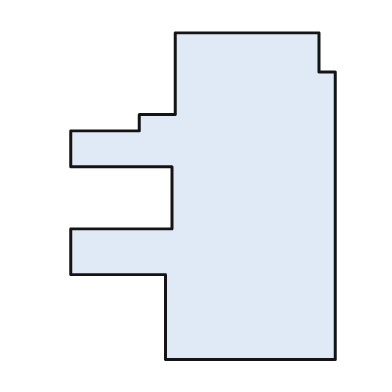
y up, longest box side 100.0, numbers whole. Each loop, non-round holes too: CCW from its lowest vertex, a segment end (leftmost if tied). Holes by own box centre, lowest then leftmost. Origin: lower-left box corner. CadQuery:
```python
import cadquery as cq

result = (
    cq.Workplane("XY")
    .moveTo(29.0, 0.0)
    .lineTo(81.0, 0.0)
    .lineTo(81.0, 88.0)
    .lineTo(76.0, 88.0)
    .lineTo(76.0, 100.0)
    .lineTo(32.0, 100.0)
    .lineTo(32.0, 75.0)
    .lineTo(21.0, 75.0)
    .lineTo(21.0, 70.0)
    .lineTo(0.0, 70.0)
    .lineTo(0.0, 59.0)
    .lineTo(31.0, 59.0)
    .lineTo(31.0, 40.0)
    .lineTo(0.0, 40.0)
    .lineTo(0.0, 26.0)
    .lineTo(29.0, 26.0)
    .close()
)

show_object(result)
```